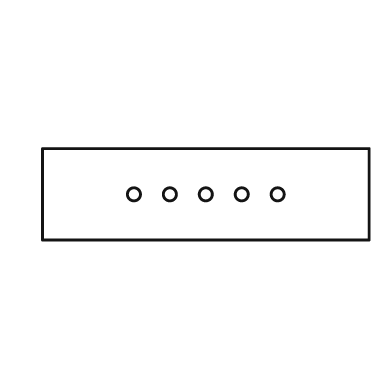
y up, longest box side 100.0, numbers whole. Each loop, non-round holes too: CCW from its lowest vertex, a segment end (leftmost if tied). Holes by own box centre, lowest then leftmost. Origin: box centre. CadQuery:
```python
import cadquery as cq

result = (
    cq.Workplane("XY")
    .moveTo(-50.0, -14.0)
    .lineTo(50.0, -14.0)
    .lineTo(50.0, 14.0)
    .lineTo(-50.0, 14.0)
    .close()
    .moveTo(-22.0, 0.0)
    .circle(2.0)
    .moveTo(-11.0, 0.0)
    .circle(2.0)
    .moveTo(0.0, 0.0)
    .circle(2.0)
    .moveTo(11.0, 0.0)
    .circle(2.0)
    .moveTo(22.0, 0.0)
    .circle(2.0)
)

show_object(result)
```